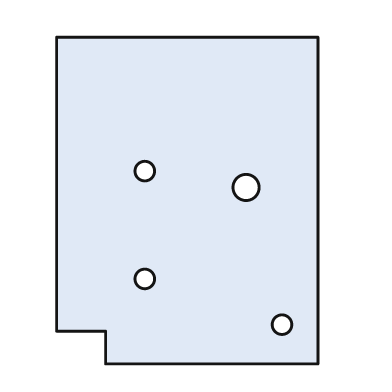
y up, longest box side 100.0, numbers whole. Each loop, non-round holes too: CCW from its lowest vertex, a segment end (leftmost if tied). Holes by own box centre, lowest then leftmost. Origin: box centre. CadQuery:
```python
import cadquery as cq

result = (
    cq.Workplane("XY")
    .moveTo(-25.0, -50.0)
    .lineTo(40.0, -50.0)
    .lineTo(40.0, 50.0)
    .lineTo(-40.0, 50.0)
    .lineTo(-40.0, -40.0)
    .lineTo(-25.0, -40.0)
    .close()
    .moveTo(29.0, -38.0)
    .circle(3.0)
    .moveTo(-13.0, -24.0)
    .circle(3.0)
    .moveTo(18.0, 4.0)
    .circle(4.0)
    .moveTo(-13.0, 9.0)
    .circle(3.0)
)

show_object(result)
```